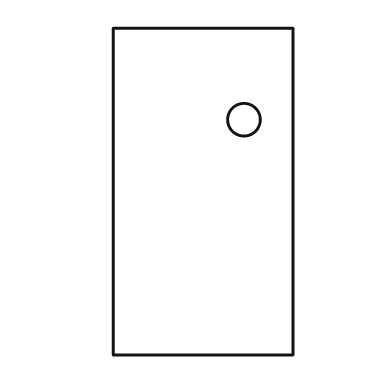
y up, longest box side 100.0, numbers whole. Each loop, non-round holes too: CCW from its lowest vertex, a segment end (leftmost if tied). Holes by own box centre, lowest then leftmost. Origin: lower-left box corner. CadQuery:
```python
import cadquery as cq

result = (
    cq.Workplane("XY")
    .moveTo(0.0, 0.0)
    .lineTo(55.0, 0.0)
    .lineTo(55.0, 100.0)
    .lineTo(0.0, 100.0)
    .close()
    .moveTo(40.0, 72.0)
    .circle(5.0)
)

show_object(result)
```